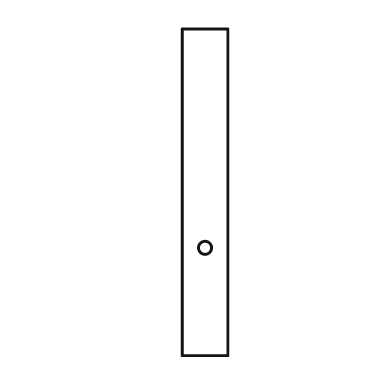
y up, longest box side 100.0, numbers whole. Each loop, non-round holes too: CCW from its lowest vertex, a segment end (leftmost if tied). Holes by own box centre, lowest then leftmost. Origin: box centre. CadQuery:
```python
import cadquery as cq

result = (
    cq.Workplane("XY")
    .moveTo(-7.0, -50.0)
    .lineTo(7.0, -50.0)
    .lineTo(7.0, 50.0)
    .lineTo(-7.0, 50.0)
    .close()
    .moveTo(0.0, -17.0)
    .circle(2.0)
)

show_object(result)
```